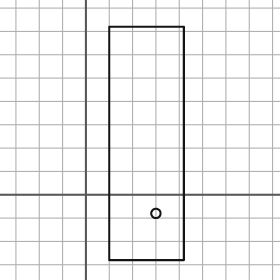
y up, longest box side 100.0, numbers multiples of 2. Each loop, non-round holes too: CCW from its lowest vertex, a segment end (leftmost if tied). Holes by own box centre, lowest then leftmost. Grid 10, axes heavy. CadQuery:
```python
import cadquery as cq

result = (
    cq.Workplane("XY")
    .moveTo(10.0, -28.0)
    .lineTo(42.0, -28.0)
    .lineTo(42.0, 72.0)
    .lineTo(10.0, 72.0)
    .close()
    .moveTo(30.0, -8.0)
    .circle(2.0)
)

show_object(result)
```